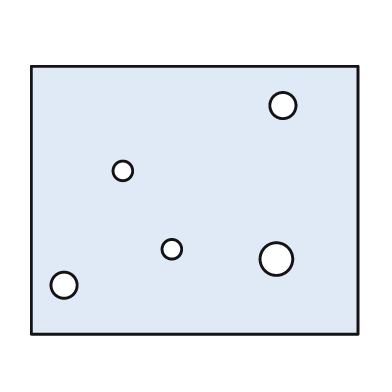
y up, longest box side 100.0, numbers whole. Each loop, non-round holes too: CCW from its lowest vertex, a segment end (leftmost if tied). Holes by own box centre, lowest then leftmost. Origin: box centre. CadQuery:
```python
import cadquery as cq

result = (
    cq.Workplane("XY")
    .moveTo(-50.0, -41.0)
    .lineTo(50.0, -41.0)
    .lineTo(50.0, 41.0)
    .lineTo(-50.0, 41.0)
    .close()
    .moveTo(-40.0, -26.0)
    .circle(4.0)
    .moveTo(25.0, -18.0)
    .circle(5.0)
    .moveTo(-7.0, -15.0)
    .circle(3.0)
    .moveTo(-22.0, 9.0)
    .circle(3.0)
    .moveTo(27.0, 29.0)
    .circle(4.0)
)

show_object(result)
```